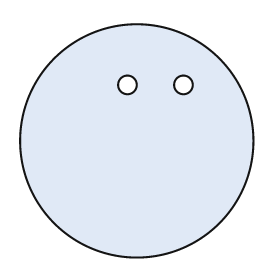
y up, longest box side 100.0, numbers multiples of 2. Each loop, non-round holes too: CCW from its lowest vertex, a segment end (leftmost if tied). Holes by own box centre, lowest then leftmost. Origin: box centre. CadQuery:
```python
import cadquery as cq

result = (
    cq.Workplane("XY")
    .moveTo(0.0, 0.0)
    .circle(50.0)
    .moveTo(-4.0, 24.0)
    .circle(4.0)
    .moveTo(20.0, 24.0)
    .circle(4.0)
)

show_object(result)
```